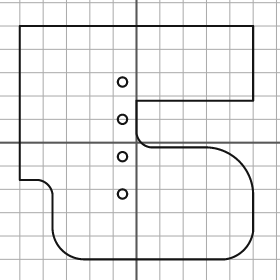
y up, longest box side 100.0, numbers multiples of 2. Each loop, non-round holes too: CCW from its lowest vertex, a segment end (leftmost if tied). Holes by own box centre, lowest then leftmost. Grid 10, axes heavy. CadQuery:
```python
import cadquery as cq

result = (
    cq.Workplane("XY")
    .moveTo(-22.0, -50.0)
    .lineTo(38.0, -50.0)
    .threePointArc((46.0, -46.0), (50.0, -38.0))
    .lineTo(50.0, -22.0)
    .threePointArc((44.0, -8.0), (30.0, -2.0))
    .lineTo(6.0, -2.0)
    .threePointArc((2.0, 0.0), (0.0, 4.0))
    .lineTo(0.0, 18.0)
    .lineTo(50.0, 18.0)
    .lineTo(50.0, 50.0)
    .lineTo(-50.0, 50.0)
    .lineTo(-50.0, -16.0)
    .lineTo(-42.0, -16.0)
    .threePointArc((-38.0, -18.0), (-36.0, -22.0))
    .lineTo(-36.0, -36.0)
    .threePointArc((-32.0, -46.0), (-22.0, -50.0))
    .close()
    .moveTo(-6.0, -22.0)
    .circle(2.0)
    .moveTo(-6.0, -6.0)
    .circle(2.0)
    .moveTo(-6.0, 10.0)
    .circle(2.0)
    .moveTo(-6.0, 26.0)
    .circle(2.0)
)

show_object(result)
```